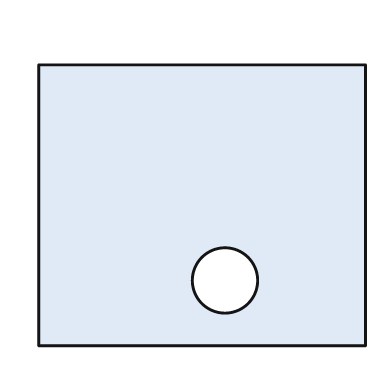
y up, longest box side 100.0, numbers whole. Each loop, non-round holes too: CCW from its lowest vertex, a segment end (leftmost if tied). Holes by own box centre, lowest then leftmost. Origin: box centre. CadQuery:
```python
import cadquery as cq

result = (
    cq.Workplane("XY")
    .moveTo(-50.0, -43.0)
    .lineTo(50.0, -43.0)
    .lineTo(50.0, 43.0)
    .lineTo(-50.0, 43.0)
    .close()
    .moveTo(7.0, -23.0)
    .circle(10.0)
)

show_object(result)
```